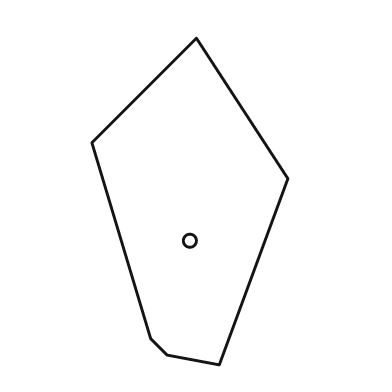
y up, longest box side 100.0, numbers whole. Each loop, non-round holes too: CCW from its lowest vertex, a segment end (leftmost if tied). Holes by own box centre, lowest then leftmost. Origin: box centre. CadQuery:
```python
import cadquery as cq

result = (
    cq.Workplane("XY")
    .moveTo(9.0, -50.0)
    .lineTo(30.0, 7.0)
    .lineTo(2.0, 50.0)
    .lineTo(-30.0, 18.0)
    .lineTo(-12.0, -42.0)
    .lineTo(-7.0, -47.0)
    .close()
    .moveTo(0.0, -12.0)
    .circle(2.0)
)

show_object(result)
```